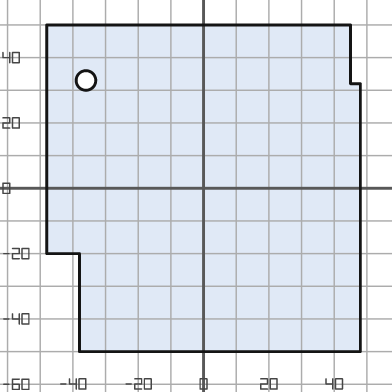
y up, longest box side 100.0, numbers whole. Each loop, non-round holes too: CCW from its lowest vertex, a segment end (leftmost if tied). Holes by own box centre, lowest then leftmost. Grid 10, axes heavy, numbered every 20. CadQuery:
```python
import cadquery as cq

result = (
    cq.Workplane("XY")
    .moveTo(-38.0, -50.0)
    .lineTo(48.0, -50.0)
    .lineTo(48.0, 32.0)
    .lineTo(45.0, 32.0)
    .lineTo(45.0, 50.0)
    .lineTo(-48.0, 50.0)
    .lineTo(-48.0, -20.0)
    .lineTo(-38.0, -20.0)
    .close()
    .moveTo(-36.0, 33.0)
    .circle(3.0)
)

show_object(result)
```